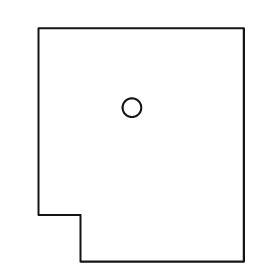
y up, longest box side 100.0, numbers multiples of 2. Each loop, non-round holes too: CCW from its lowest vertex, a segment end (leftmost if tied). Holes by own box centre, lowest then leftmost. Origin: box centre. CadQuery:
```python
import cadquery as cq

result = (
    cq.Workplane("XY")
    .moveTo(-26.0, -50.0)
    .lineTo(44.0, -50.0)
    .lineTo(44.0, 50.0)
    .lineTo(-44.0, 50.0)
    .lineTo(-44.0, -30.0)
    .lineTo(-26.0, -30.0)
    .close()
    .moveTo(-4.0, 16.0)
    .circle(4.0)
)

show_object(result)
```